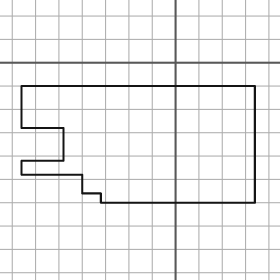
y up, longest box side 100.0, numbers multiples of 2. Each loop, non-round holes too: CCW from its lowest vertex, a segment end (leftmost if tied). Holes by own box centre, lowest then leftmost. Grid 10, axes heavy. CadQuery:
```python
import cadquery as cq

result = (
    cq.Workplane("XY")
    .moveTo(-32.0, -60.0)
    .lineTo(34.0, -60.0)
    .lineTo(34.0, -10.0)
    .lineTo(-66.0, -10.0)
    .lineTo(-66.0, -28.0)
    .lineTo(-48.0, -28.0)
    .lineTo(-48.0, -42.0)
    .lineTo(-66.0, -42.0)
    .lineTo(-66.0, -48.0)
    .lineTo(-40.0, -48.0)
    .lineTo(-40.0, -56.0)
    .lineTo(-32.0, -56.0)
    .close()
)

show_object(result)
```